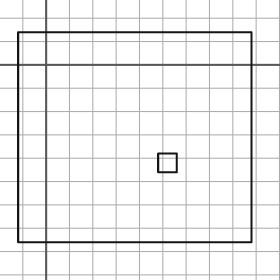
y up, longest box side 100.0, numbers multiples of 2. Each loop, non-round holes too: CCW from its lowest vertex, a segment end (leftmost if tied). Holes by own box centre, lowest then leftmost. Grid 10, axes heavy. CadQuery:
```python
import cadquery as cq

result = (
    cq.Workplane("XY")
    .moveTo(-12.0, -76.0)
    .lineTo(88.0, -76.0)
    .lineTo(88.0, 14.0)
    .lineTo(-12.0, 14.0)
    .close()
    .moveTo(48.0, -46.0)
    .lineTo(56.0, -46.0)
    .lineTo(56.0, -38.0)
    .lineTo(48.0, -38.0)
    .close()
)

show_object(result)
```